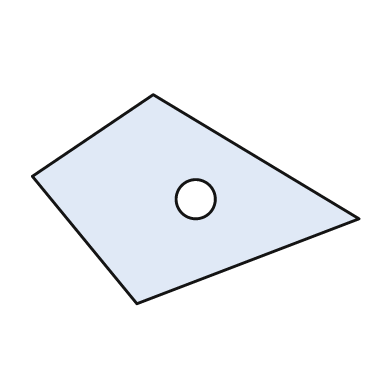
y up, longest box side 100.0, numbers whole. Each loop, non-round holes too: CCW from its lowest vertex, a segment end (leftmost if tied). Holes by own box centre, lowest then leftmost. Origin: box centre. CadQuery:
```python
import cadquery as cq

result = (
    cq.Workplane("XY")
    .moveTo(-18.0, -32.0)
    .lineTo(50.0, -6.0)
    .lineTo(-13.0, 32.0)
    .lineTo(-50.0, 7.0)
    .close()
    .moveTo(0.0, 0.0)
    .circle(6.0)
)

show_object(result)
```